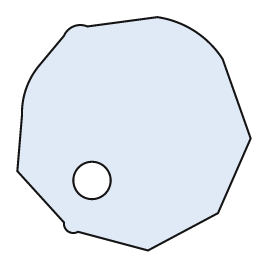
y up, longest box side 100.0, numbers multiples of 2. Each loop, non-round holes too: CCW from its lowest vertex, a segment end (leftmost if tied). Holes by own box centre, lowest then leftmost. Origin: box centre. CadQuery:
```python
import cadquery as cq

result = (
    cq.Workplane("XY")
    .moveTo(6.0, -50.0)
    .lineTo(36.0, -34.0)
    .lineTo(50.0, -2.0)
    .lineTo(38.0, 32.0)
    .threePointArc((26.0, 44.0), (10.0, 50.0))
    .lineTo(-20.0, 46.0)
    .threePointArc((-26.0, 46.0), (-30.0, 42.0))
    .lineTo(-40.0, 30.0)
    .threePointArc((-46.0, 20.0), (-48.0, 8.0))
    .lineTo(-50.0, -16.0)
    .lineTo(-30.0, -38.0)
    .threePointArc((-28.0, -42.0), (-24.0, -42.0))
    .close()
    .moveTo(-18.0, -20.0)
    .circle(8.0)
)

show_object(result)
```